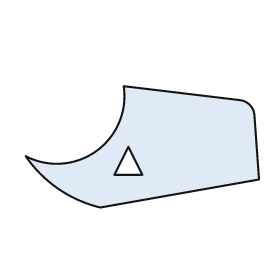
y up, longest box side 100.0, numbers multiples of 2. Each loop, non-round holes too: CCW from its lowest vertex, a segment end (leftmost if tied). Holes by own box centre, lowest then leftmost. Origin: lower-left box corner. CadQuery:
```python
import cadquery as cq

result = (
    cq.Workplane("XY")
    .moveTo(32.0, 0.0)
    .lineTo(100.0, 12.0)
    .lineTo(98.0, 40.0)
    .threePointArc((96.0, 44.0), (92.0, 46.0))
    .lineTo(42.0, 52.0)
    .threePointArc((30.0, 24.0), (0.0, 22.0))
    .threePointArc((14.0, 8.0), (32.0, 0.0))
    .close()
    .moveTo(38.0, 14.0)
    .lineTo(50.0, 14.0)
    .lineTo(44.0, 26.0)
    .close()
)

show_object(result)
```